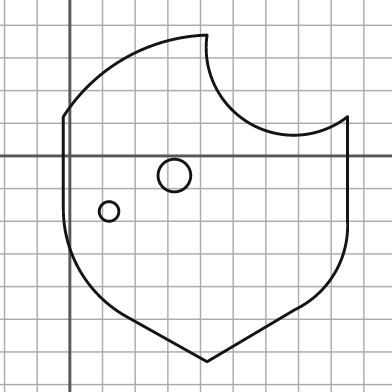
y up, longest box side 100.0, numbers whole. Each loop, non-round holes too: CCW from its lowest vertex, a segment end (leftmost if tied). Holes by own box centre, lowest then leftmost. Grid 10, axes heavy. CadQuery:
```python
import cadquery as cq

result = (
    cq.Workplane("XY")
    .moveTo(42.0, -63.0)
    .lineTo(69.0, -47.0)
    .threePointArc((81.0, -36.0), (85.0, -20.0))
    .lineTo(85.0, 12.0)
    .threePointArc((55.0, 10.0), (42.0, 37.0))
    .threePointArc((17.0, 30.0), (-2.0, 12.0))
    .lineTo(-2.0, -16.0)
    .threePointArc((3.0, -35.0), (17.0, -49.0))
    .close()
    .moveTo(12.0, -17.0)
    .circle(3.0)
    .moveTo(32.0, -6.0)
    .circle(5.0)
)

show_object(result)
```